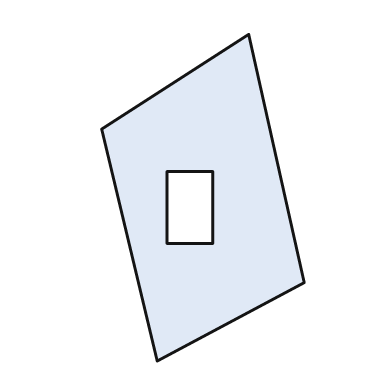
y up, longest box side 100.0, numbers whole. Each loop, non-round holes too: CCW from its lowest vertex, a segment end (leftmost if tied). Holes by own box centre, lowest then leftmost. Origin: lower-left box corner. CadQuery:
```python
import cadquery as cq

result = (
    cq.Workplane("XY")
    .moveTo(17.0, 0.0)
    .lineTo(62.0, 24.0)
    .lineTo(45.0, 100.0)
    .lineTo(0.0, 71.0)
    .close()
    .moveTo(20.0, 36.0)
    .lineTo(34.0, 36.0)
    .lineTo(34.0, 58.0)
    .lineTo(20.0, 58.0)
    .close()
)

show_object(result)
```